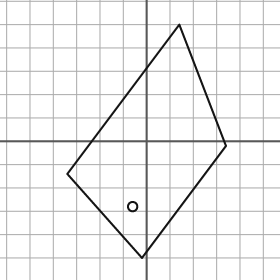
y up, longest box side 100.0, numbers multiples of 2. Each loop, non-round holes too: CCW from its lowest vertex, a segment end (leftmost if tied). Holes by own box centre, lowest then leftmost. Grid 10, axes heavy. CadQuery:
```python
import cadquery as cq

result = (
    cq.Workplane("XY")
    .moveTo(-2.0, -50.0)
    .lineTo(34.0, -2.0)
    .lineTo(14.0, 50.0)
    .lineTo(-34.0, -14.0)
    .close()
    .moveTo(-6.0, -28.0)
    .circle(2.0)
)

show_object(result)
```